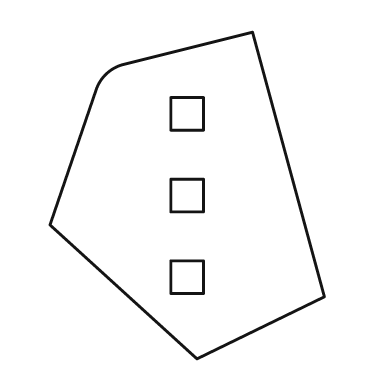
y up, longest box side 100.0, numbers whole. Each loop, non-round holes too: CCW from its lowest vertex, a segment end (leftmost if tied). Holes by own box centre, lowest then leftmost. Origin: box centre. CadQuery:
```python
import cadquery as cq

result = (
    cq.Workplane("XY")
    .moveTo(3.0, -50.0)
    .lineTo(42.0, -31.0)
    .lineTo(20.0, 50.0)
    .lineTo(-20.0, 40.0)
    .threePointArc((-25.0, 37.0), (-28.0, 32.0))
    .lineTo(-42.0, -9.0)
    .close()
    .moveTo(-5.0, -30.0)
    .lineTo(5.0, -30.0)
    .lineTo(5.0, -20.0)
    .lineTo(-5.0, -20.0)
    .close()
    .moveTo(-5.0, -5.0)
    .lineTo(5.0, -5.0)
    .lineTo(5.0, 5.0)
    .lineTo(-5.0, 5.0)
    .close()
    .moveTo(-5.0, 20.0)
    .lineTo(5.0, 20.0)
    .lineTo(5.0, 30.0)
    .lineTo(-5.0, 30.0)
    .close()
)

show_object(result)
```